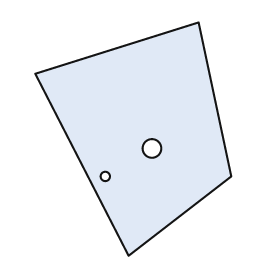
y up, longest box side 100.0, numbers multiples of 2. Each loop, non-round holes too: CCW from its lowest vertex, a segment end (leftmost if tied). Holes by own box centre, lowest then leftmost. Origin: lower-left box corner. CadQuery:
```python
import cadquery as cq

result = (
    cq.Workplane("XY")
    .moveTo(40.0, 0.0)
    .lineTo(84.0, 34.0)
    .lineTo(70.0, 100.0)
    .lineTo(0.0, 78.0)
    .close()
    .moveTo(30.0, 34.0)
    .circle(2.0)
    .moveTo(50.0, 46.0)
    .circle(4.0)
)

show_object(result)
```